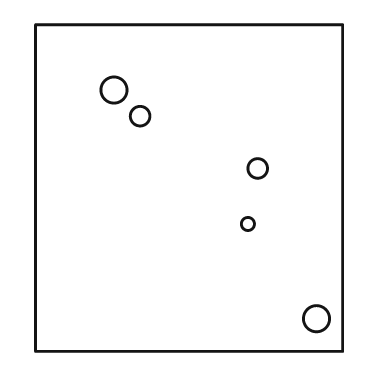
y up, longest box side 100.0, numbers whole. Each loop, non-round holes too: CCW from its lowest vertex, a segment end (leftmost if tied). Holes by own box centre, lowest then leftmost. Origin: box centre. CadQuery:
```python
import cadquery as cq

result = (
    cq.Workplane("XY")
    .moveTo(-47.0, -50.0)
    .lineTo(47.0, -50.0)
    .lineTo(47.0, 50.0)
    .lineTo(-47.0, 50.0)
    .close()
    .moveTo(39.0, -40.0)
    .circle(4.0)
    .moveTo(18.0, -11.0)
    .circle(2.0)
    .moveTo(21.0, 6.0)
    .circle(3.0)
    .moveTo(-15.0, 22.0)
    .circle(3.0)
    .moveTo(-23.0, 30.0)
    .circle(4.0)
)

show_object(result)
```